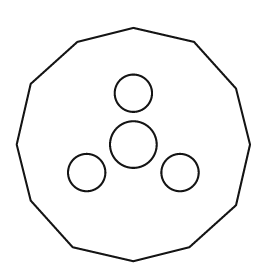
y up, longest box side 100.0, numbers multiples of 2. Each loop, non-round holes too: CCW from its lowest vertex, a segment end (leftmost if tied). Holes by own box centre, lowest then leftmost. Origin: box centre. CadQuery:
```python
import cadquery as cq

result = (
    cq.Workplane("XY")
    .moveTo(0.0, -50.0)
    .lineTo(24.0, -44.0)
    .lineTo(44.0, -26.0)
    .lineTo(50.0, 0.0)
    .lineTo(44.0, 24.0)
    .lineTo(26.0, 44.0)
    .lineTo(0.0, 50.0)
    .lineTo(-24.0, 44.0)
    .lineTo(-44.0, 26.0)
    .lineTo(-50.0, 0.0)
    .lineTo(-44.0, -24.0)
    .lineTo(-26.0, -44.0)
    .close()
    .moveTo(-20.0, -12.0)
    .circle(8.0)
    .moveTo(20.0, -12.0)
    .circle(8.0)
    .moveTo(0.0, 0.0)
    .circle(10.0)
    .moveTo(0.0, 22.0)
    .circle(8.0)
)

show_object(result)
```